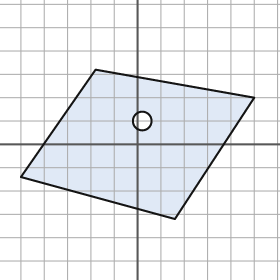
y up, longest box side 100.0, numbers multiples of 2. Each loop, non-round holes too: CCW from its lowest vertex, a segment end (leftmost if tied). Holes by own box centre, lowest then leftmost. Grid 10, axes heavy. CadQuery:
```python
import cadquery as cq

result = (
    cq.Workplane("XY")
    .moveTo(16.0, -32.0)
    .lineTo(50.0, 20.0)
    .lineTo(-18.0, 32.0)
    .lineTo(-50.0, -14.0)
    .close()
    .moveTo(2.0, 10.0)
    .circle(4.0)
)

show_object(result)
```